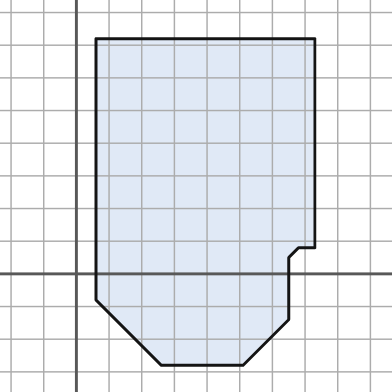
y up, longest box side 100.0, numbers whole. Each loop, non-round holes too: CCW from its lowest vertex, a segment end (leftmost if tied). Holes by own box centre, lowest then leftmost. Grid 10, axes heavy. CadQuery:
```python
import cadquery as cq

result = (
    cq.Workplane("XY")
    .moveTo(26.0, -28.0)
    .lineTo(51.0, -28.0)
    .lineTo(65.0, -14.0)
    .lineTo(65.0, 5.0)
    .lineTo(68.0, 8.0)
    .lineTo(73.0, 8.0)
    .lineTo(73.0, 72.0)
    .lineTo(6.0, 72.0)
    .lineTo(6.0, -8.0)
    .close()
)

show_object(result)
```